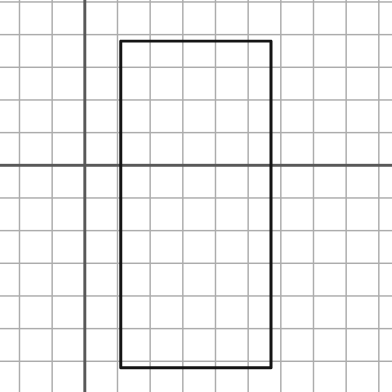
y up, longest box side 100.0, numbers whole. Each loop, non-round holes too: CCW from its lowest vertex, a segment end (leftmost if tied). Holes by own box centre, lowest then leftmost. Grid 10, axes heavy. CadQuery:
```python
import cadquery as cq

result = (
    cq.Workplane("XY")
    .moveTo(11.0, -62.0)
    .lineTo(57.0, -62.0)
    .lineTo(57.0, 38.0)
    .lineTo(11.0, 38.0)
    .close()
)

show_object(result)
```